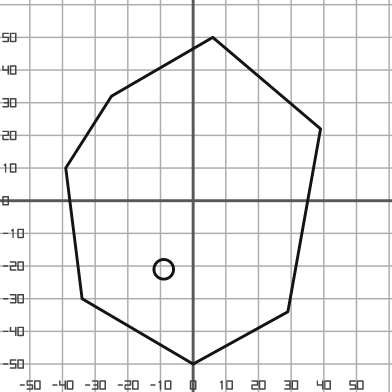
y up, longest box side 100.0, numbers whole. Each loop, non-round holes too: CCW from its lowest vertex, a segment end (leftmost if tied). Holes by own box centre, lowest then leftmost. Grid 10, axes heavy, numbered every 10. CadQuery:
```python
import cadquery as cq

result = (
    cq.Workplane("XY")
    .moveTo(0.0, -50.0)
    .lineTo(29.0, -34.0)
    .lineTo(39.0, 22.0)
    .lineTo(6.0, 50.0)
    .lineTo(-25.0, 32.0)
    .lineTo(-39.0, 10.0)
    .lineTo(-34.0, -30.0)
    .close()
    .moveTo(-9.0, -21.0)
    .circle(3.0)
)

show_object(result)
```